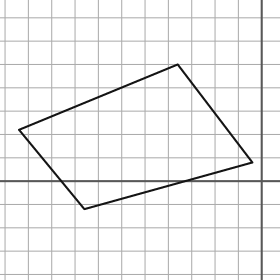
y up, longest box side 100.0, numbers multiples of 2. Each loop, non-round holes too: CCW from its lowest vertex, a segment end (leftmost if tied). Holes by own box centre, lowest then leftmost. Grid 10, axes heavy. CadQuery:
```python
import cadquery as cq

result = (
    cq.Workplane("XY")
    .moveTo(-76.0, -12.0)
    .lineTo(-4.0, 8.0)
    .lineTo(-36.0, 50.0)
    .lineTo(-104.0, 22.0)
    .close()
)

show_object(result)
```